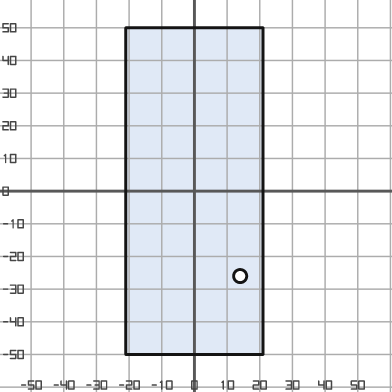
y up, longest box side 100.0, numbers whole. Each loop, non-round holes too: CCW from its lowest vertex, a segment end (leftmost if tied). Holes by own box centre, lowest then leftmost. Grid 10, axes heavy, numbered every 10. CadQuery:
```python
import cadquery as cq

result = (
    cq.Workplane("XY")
    .moveTo(-21.0, -50.0)
    .lineTo(21.0, -50.0)
    .lineTo(21.0, 50.0)
    .lineTo(-21.0, 50.0)
    .close()
    .moveTo(14.0, -26.0)
    .circle(2.0)
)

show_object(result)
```